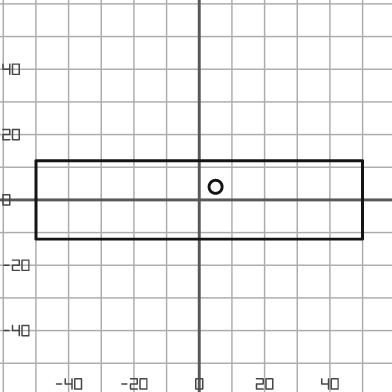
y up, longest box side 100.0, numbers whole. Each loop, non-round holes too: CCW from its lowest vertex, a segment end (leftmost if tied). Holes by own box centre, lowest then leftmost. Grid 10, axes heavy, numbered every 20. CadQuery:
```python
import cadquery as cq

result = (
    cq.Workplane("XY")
    .moveTo(-50.0, -12.0)
    .lineTo(50.0, -12.0)
    .lineTo(50.0, 12.0)
    .lineTo(-50.0, 12.0)
    .close()
    .moveTo(5.0, 4.0)
    .circle(2.0)
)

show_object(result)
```